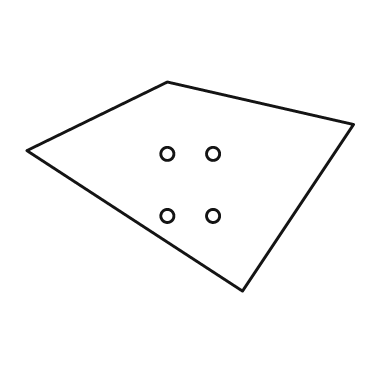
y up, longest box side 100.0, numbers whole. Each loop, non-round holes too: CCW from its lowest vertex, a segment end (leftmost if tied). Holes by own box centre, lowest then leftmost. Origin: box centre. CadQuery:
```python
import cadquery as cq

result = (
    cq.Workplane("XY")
    .moveTo(16.0, -32.0)
    .lineTo(50.0, 19.0)
    .lineTo(-7.0, 32.0)
    .lineTo(-50.0, 11.0)
    .close()
    .moveTo(-7.0, -9.0)
    .circle(2.0)
    .moveTo(7.0, -9.0)
    .circle(2.0)
    .moveTo(-7.0, 10.0)
    .circle(2.0)
    .moveTo(7.0, 10.0)
    .circle(2.0)
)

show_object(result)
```